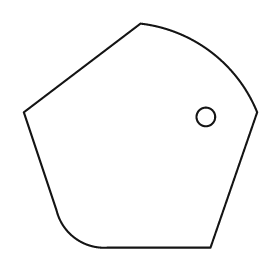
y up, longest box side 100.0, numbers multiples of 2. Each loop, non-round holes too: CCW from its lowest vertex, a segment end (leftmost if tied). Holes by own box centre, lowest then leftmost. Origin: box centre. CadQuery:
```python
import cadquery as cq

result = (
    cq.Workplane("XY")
    .moveTo(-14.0, -48.0)
    .lineTo(30.0, -48.0)
    .lineTo(50.0, 10.0)
    .threePointArc((30.0, 36.0), (0.0, 48.0))
    .lineTo(-50.0, 10.0)
    .lineTo(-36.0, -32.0)
    .threePointArc((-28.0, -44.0), (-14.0, -48.0))
    .close()
    .moveTo(28.0, 8.0)
    .circle(4.0)
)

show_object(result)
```